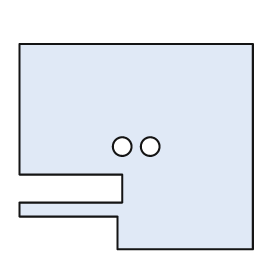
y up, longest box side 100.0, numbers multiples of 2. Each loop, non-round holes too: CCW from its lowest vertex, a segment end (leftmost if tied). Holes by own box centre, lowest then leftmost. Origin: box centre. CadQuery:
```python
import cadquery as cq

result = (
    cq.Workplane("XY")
    .moveTo(-8.0, -44.0)
    .lineTo(50.0, -44.0)
    .lineTo(50.0, 44.0)
    .lineTo(-50.0, 44.0)
    .lineTo(-50.0, -12.0)
    .lineTo(-6.0, -12.0)
    .lineTo(-6.0, -24.0)
    .lineTo(-50.0, -24.0)
    .lineTo(-50.0, -30.0)
    .lineTo(-8.0, -30.0)
    .close()
    .moveTo(-6.0, 0.0)
    .circle(4.0)
    .moveTo(6.0, 0.0)
    .circle(4.0)
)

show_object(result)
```